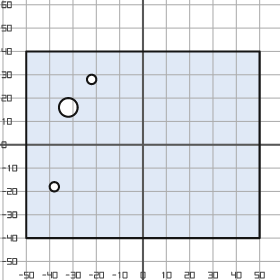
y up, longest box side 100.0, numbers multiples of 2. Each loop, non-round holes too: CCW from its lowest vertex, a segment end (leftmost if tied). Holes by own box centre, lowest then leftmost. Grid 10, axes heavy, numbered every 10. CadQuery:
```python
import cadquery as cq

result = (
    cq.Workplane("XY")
    .moveTo(-50.0, -40.0)
    .lineTo(50.0, -40.0)
    .lineTo(50.0, 40.0)
    .lineTo(-50.0, 40.0)
    .close()
    .moveTo(-38.0, -18.0)
    .circle(2.0)
    .moveTo(-32.0, 16.0)
    .circle(4.0)
    .moveTo(-22.0, 28.0)
    .circle(2.0)
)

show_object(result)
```